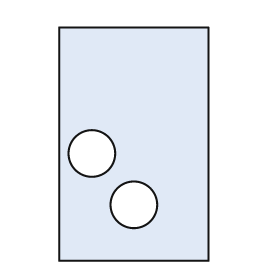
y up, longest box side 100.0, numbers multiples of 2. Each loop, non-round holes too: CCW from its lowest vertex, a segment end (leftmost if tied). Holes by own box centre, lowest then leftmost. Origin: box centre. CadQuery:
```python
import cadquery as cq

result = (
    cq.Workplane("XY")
    .moveTo(-32.0, -50.0)
    .lineTo(32.0, -50.0)
    .lineTo(32.0, 50.0)
    .lineTo(-32.0, 50.0)
    .close()
    .moveTo(0.0, -26.0)
    .circle(10.0)
    .moveTo(-18.0, -4.0)
    .circle(10.0)
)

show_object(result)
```